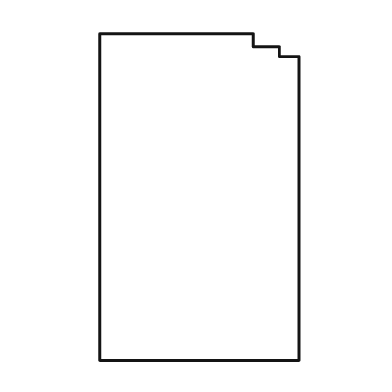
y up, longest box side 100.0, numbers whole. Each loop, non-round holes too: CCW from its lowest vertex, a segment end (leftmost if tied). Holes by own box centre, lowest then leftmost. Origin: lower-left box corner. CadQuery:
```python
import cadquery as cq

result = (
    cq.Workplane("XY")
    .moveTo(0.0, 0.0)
    .lineTo(61.0, 0.0)
    .lineTo(61.0, 93.0)
    .lineTo(55.0, 93.0)
    .lineTo(55.0, 96.0)
    .lineTo(47.0, 96.0)
    .lineTo(47.0, 100.0)
    .lineTo(0.0, 100.0)
    .close()
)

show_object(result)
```